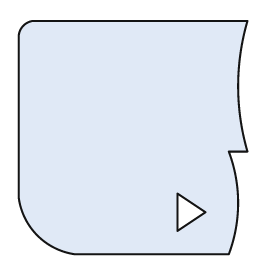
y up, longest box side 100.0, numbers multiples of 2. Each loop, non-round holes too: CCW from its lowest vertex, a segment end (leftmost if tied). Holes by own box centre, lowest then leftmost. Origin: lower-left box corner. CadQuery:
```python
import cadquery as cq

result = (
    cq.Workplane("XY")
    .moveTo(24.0, 0.0)
    .lineTo(90.0, 0.0)
    .threePointArc((94.0, 22.0), (90.0, 44.0))
    .lineTo(98.0, 44.0)
    .threePointArc((94.0, 72.0), (98.0, 100.0))
    .lineTo(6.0, 100.0)
    .threePointArc((2.0, 98.0), (0.0, 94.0))
    .lineTo(0.0, 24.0)
    .threePointArc((8.0, 8.0), (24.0, 0.0))
    .close()
    .moveTo(68.0, 10.0)
    .lineTo(80.0, 18.0)
    .lineTo(68.0, 26.0)
    .close()
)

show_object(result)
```